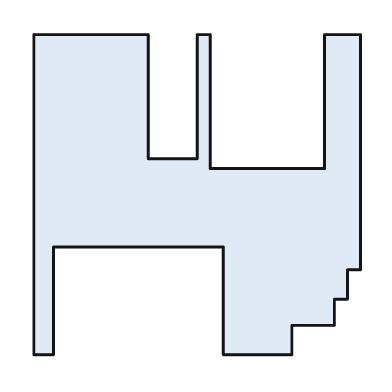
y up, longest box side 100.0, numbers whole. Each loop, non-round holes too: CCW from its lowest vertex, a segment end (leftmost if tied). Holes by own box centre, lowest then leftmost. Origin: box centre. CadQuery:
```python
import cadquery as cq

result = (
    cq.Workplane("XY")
    .moveTo(-50.0, -49.0)
    .lineTo(-44.0, -49.0)
    .lineTo(-44.0, -16.0)
    .lineTo(8.0, -16.0)
    .lineTo(8.0, -49.0)
    .lineTo(29.0, -49.0)
    .lineTo(29.0, -40.0)
    .lineTo(42.0, -40.0)
    .lineTo(42.0, -32.0)
    .lineTo(46.0, -32.0)
    .lineTo(46.0, -23.0)
    .lineTo(50.0, -23.0)
    .lineTo(50.0, 49.0)
    .lineTo(39.0, 49.0)
    .lineTo(39.0, 8.0)
    .lineTo(4.0, 8.0)
    .lineTo(4.0, 49.0)
    .lineTo(0.0, 49.0)
    .lineTo(0.0, 11.0)
    .lineTo(-15.0, 11.0)
    .lineTo(-15.0, 49.0)
    .lineTo(-50.0, 49.0)
    .close()
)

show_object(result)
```